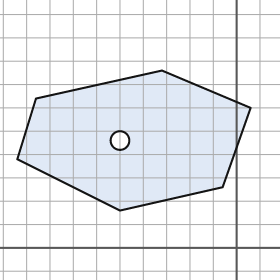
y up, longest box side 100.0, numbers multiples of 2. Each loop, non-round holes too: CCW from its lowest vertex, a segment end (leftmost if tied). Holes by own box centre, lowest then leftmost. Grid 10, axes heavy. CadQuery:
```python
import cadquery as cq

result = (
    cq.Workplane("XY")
    .moveTo(-50.0, 16.0)
    .lineTo(-6.0, 26.0)
    .lineTo(6.0, 60.0)
    .lineTo(-32.0, 76.0)
    .lineTo(-86.0, 64.0)
    .lineTo(-94.0, 38.0)
    .close()
    .moveTo(-50.0, 46.0)
    .circle(4.0)
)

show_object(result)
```